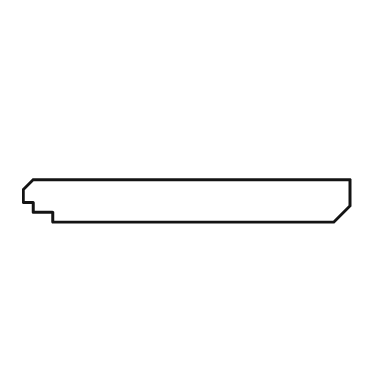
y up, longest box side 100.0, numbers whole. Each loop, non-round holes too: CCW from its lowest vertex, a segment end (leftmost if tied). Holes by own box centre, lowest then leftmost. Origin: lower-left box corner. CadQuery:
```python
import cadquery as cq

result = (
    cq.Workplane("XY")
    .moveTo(9.0, 0.0)
    .lineTo(95.0, 0.0)
    .lineTo(100.0, 5.0)
    .lineTo(100.0, 13.0)
    .lineTo(3.0, 13.0)
    .lineTo(0.0, 10.0)
    .lineTo(0.0, 6.0)
    .lineTo(3.0, 6.0)
    .lineTo(3.0, 3.0)
    .lineTo(9.0, 3.0)
    .close()
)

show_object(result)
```